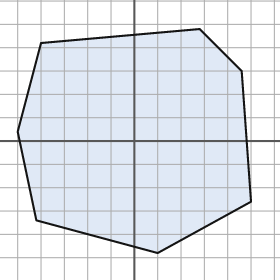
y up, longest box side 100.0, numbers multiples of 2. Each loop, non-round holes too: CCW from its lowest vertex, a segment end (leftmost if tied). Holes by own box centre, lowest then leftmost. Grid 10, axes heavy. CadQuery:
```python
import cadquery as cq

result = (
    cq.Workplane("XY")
    .moveTo(10.0, -48.0)
    .lineTo(50.0, -26.0)
    .lineTo(46.0, 30.0)
    .lineTo(28.0, 48.0)
    .lineTo(-40.0, 42.0)
    .lineTo(-50.0, 4.0)
    .lineTo(-42.0, -34.0)
    .close()
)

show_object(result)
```